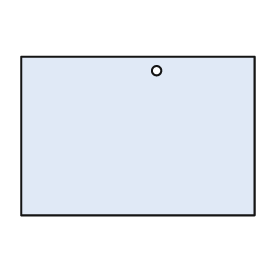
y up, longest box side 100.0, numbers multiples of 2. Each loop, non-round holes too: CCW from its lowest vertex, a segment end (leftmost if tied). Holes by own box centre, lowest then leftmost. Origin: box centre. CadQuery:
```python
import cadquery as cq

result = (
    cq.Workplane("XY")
    .moveTo(-50.0, -34.0)
    .lineTo(50.0, -34.0)
    .lineTo(50.0, 34.0)
    .lineTo(-50.0, 34.0)
    .close()
    .moveTo(8.0, 28.0)
    .circle(2.0)
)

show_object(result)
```